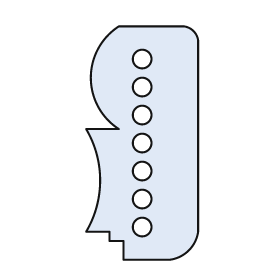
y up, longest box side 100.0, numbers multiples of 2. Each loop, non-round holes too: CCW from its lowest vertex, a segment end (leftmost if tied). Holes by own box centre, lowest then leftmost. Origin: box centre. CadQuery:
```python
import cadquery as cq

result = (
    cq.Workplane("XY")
    .moveTo(-8.0, -50.0)
    .lineTo(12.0, -50.0)
    .threePointArc((20.0, -46.0), (24.0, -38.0))
    .lineTo(24.0, 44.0)
    .threePointArc((22.0, 48.0), (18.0, 50.0))
    .lineTo(-10.0, 50.0)
    .threePointArc((-22.0, 28.0), (-10.0, 6.0))
    .lineTo(-24.0, 6.0)
    .threePointArc((-18.0, -16.0), (-24.0, -38.0))
    .lineTo(-14.0, -38.0)
    .lineTo(-14.0, -42.0)
    .lineTo(-8.0, -42.0)
    .close()
    .moveTo(0.0, -36.0)
    .circle(4.0)
    .moveTo(0.0, -24.0)
    .circle(4.0)
    .moveTo(0.0, -12.0)
    .circle(4.0)
    .moveTo(0.0, 0.0)
    .circle(4.0)
    .moveTo(0.0, 12.0)
    .circle(4.0)
    .moveTo(0.0, 24.0)
    .circle(4.0)
    .moveTo(0.0, 36.0)
    .circle(4.0)
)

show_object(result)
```